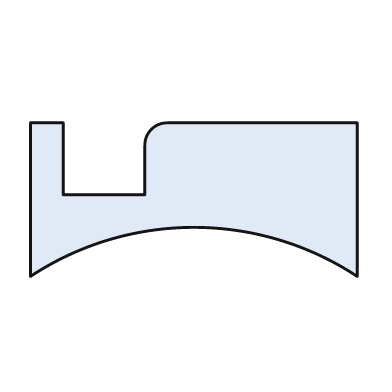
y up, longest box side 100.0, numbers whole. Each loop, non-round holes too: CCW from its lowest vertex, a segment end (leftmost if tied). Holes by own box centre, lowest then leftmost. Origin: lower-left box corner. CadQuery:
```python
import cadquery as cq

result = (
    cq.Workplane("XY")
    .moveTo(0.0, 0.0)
    .threePointArc((50.0, 15.0), (100.0, 0.0))
    .lineTo(100.0, 47.0)
    .lineTo(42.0, 47.0)
    .threePointArc((37.0, 45.0), (35.0, 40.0))
    .lineTo(35.0, 25.0)
    .lineTo(10.0, 25.0)
    .lineTo(10.0, 47.0)
    .lineTo(0.0, 47.0)
    .close()
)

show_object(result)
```